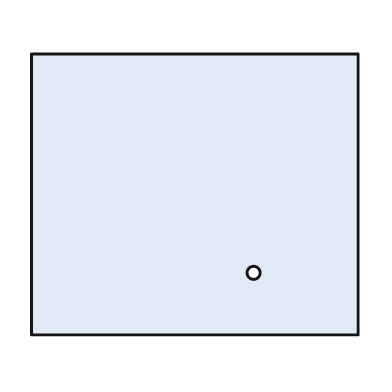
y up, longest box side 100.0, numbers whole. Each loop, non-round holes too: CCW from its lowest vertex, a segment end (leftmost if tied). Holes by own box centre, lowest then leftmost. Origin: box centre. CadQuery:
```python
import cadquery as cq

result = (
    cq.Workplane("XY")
    .moveTo(-50.0, -43.0)
    .lineTo(50.0, -43.0)
    .lineTo(50.0, 43.0)
    .lineTo(-50.0, 43.0)
    .close()
    .moveTo(18.0, -24.0)
    .circle(2.0)
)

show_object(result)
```